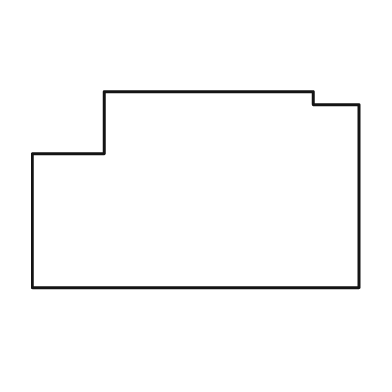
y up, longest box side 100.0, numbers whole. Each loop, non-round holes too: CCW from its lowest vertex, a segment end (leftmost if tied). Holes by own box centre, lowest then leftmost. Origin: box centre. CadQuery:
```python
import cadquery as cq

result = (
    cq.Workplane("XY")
    .moveTo(-50.0, -30.0)
    .lineTo(50.0, -30.0)
    .lineTo(50.0, 26.0)
    .lineTo(36.0, 26.0)
    .lineTo(36.0, 30.0)
    .lineTo(-28.0, 30.0)
    .lineTo(-28.0, 11.0)
    .lineTo(-50.0, 11.0)
    .close()
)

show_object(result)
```